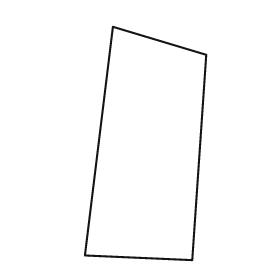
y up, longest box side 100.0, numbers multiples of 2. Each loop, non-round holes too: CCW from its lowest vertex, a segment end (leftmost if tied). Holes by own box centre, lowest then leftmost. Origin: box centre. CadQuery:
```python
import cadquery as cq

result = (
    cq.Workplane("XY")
    .moveTo(20.0, -50.0)
    .lineTo(26.0, 38.0)
    .lineTo(-14.0, 50.0)
    .lineTo(-26.0, -48.0)
    .close()
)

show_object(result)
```